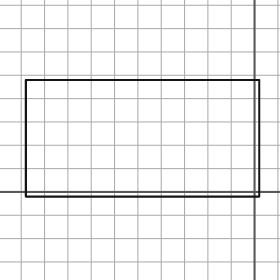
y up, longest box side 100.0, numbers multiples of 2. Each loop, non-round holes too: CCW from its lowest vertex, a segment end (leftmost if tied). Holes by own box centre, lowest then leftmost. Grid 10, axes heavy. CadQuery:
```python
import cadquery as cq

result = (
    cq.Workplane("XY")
    .moveTo(-98.0, -2.0)
    .lineTo(2.0, -2.0)
    .lineTo(2.0, 48.0)
    .lineTo(-98.0, 48.0)
    .close()
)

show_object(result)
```